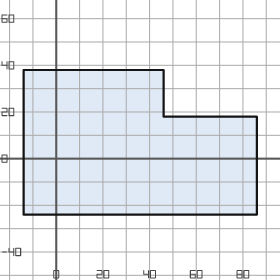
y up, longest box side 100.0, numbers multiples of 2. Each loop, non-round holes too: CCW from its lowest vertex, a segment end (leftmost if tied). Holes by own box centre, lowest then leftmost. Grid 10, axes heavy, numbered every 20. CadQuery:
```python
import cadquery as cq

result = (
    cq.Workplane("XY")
    .moveTo(-14.0, -24.0)
    .lineTo(86.0, -24.0)
    .lineTo(86.0, 18.0)
    .lineTo(46.0, 18.0)
    .lineTo(46.0, 38.0)
    .lineTo(-14.0, 38.0)
    .close()
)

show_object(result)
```